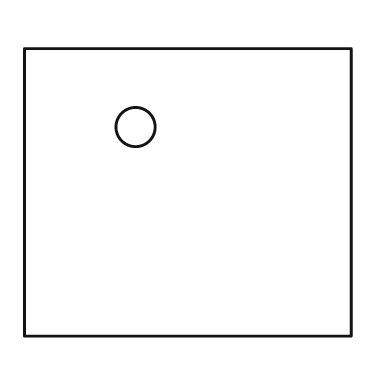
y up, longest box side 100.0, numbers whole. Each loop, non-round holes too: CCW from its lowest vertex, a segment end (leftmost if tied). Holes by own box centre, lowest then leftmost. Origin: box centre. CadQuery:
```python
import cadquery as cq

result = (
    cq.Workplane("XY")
    .moveTo(-50.0, -44.0)
    .lineTo(50.0, -44.0)
    .lineTo(50.0, 44.0)
    .lineTo(-50.0, 44.0)
    .close()
    .moveTo(-16.0, 20.0)
    .circle(6.0)
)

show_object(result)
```